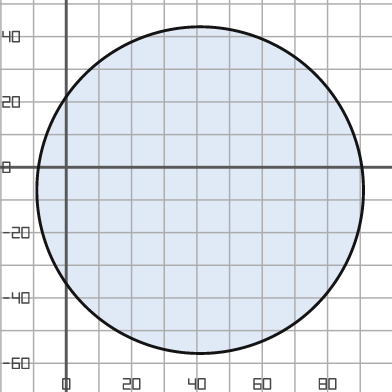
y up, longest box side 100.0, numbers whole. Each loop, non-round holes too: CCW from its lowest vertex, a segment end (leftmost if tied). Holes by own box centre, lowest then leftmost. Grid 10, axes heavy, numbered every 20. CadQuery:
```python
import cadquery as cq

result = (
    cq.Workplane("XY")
    .moveTo(41.0, -7.0)
    .circle(50.0)
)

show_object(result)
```